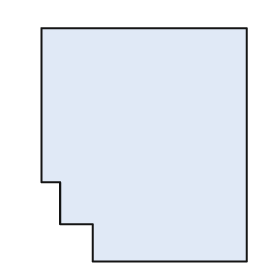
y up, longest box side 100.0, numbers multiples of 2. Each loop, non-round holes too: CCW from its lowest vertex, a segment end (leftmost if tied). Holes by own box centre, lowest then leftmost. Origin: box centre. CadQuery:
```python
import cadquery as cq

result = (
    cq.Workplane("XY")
    .moveTo(-22.0, -50.0)
    .lineTo(44.0, -50.0)
    .lineTo(44.0, 50.0)
    .lineTo(-44.0, 50.0)
    .lineTo(-44.0, -16.0)
    .lineTo(-36.0, -16.0)
    .lineTo(-36.0, -34.0)
    .lineTo(-22.0, -34.0)
    .close()
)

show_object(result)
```